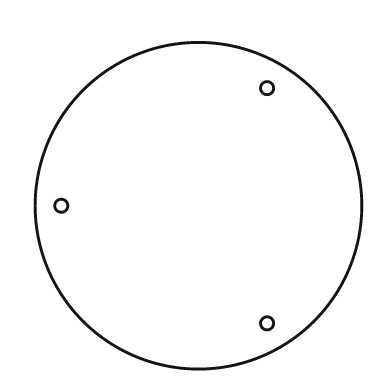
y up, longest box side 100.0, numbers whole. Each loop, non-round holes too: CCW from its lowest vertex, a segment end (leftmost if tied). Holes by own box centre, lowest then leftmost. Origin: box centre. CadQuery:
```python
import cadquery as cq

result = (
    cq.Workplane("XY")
    .moveTo(0.0, 0.0)
    .circle(50.0)
    .moveTo(21.0, -36.0)
    .circle(2.0)
    .moveTo(-42.0, 0.0)
    .circle(2.0)
    .moveTo(21.0, 36.0)
    .circle(2.0)
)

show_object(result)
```